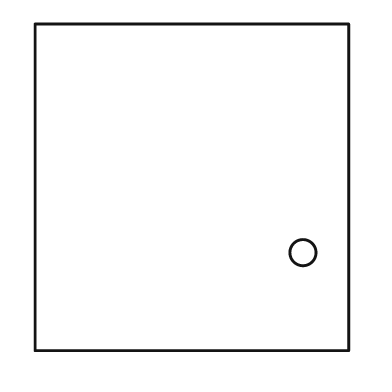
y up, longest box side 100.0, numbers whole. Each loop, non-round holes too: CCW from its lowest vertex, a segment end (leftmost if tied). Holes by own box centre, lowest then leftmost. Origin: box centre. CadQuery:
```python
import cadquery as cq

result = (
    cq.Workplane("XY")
    .moveTo(-48.0, -50.0)
    .lineTo(48.0, -50.0)
    .lineTo(48.0, 50.0)
    .lineTo(-48.0, 50.0)
    .close()
    .moveTo(34.0, -20.0)
    .circle(4.0)
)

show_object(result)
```